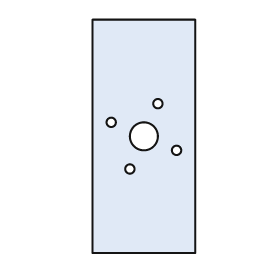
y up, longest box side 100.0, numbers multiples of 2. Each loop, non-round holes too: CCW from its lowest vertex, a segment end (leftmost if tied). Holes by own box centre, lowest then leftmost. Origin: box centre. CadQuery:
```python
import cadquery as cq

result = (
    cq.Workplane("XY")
    .moveTo(-22.0, -50.0)
    .lineTo(22.0, -50.0)
    .lineTo(22.0, 50.0)
    .lineTo(-22.0, 50.0)
    .close()
    .moveTo(-6.0, -14.0)
    .circle(2.0)
    .moveTo(14.0, -6.0)
    .circle(2.0)
    .moveTo(0.0, 0.0)
    .circle(6.0)
    .moveTo(-14.0, 6.0)
    .circle(2.0)
    .moveTo(6.0, 14.0)
    .circle(2.0)
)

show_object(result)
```